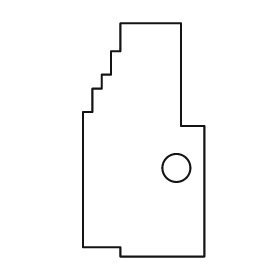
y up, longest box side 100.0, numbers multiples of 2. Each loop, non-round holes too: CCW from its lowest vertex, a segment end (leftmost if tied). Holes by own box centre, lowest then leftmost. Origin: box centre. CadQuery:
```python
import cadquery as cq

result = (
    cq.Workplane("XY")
    .moveTo(-10.0, -50.0)
    .lineTo(26.0, -50.0)
    .lineTo(26.0, 6.0)
    .lineTo(16.0, 6.0)
    .lineTo(16.0, 50.0)
    .lineTo(-10.0, 50.0)
    .lineTo(-10.0, 38.0)
    .lineTo(-14.0, 38.0)
    .lineTo(-14.0, 28.0)
    .lineTo(-18.0, 28.0)
    .lineTo(-18.0, 22.0)
    .lineTo(-22.0, 22.0)
    .lineTo(-22.0, 12.0)
    .lineTo(-26.0, 12.0)
    .lineTo(-26.0, -46.0)
    .lineTo(-10.0, -46.0)
    .close()
    .moveTo(14.0, -12.0)
    .circle(6.0)
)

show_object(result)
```